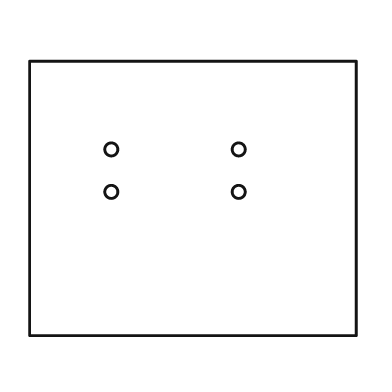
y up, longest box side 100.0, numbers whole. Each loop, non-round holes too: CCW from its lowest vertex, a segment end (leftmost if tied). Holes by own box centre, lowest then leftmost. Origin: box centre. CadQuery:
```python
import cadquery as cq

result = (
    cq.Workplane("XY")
    .moveTo(-50.0, -42.0)
    .lineTo(50.0, -42.0)
    .lineTo(50.0, 42.0)
    .lineTo(-50.0, 42.0)
    .close()
    .moveTo(-25.0, 2.0)
    .circle(2.0)
    .moveTo(14.0, 2.0)
    .circle(2.0)
    .moveTo(-25.0, 15.0)
    .circle(2.0)
    .moveTo(14.0, 15.0)
    .circle(2.0)
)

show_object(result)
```